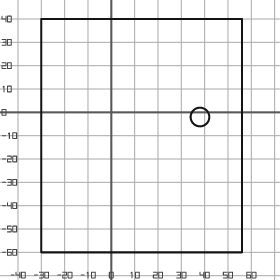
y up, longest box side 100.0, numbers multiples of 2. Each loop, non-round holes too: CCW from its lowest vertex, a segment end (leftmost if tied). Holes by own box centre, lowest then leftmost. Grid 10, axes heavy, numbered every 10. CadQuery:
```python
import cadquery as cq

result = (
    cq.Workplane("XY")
    .moveTo(-30.0, -60.0)
    .lineTo(56.0, -60.0)
    .lineTo(56.0, 40.0)
    .lineTo(-30.0, 40.0)
    .close()
    .moveTo(38.0, -2.0)
    .circle(4.0)
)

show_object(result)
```